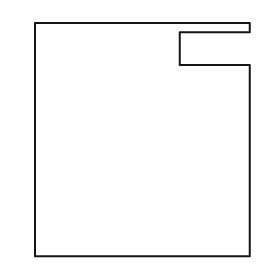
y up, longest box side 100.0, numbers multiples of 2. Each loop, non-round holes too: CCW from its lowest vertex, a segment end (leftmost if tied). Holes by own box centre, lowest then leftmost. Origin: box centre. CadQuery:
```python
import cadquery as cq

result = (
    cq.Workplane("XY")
    .moveTo(-46.0, -50.0)
    .lineTo(46.0, -50.0)
    .lineTo(46.0, 32.0)
    .lineTo(16.0, 32.0)
    .lineTo(16.0, 46.0)
    .lineTo(46.0, 46.0)
    .lineTo(46.0, 50.0)
    .lineTo(-46.0, 50.0)
    .close()
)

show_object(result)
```